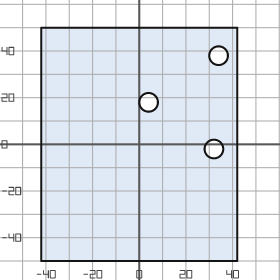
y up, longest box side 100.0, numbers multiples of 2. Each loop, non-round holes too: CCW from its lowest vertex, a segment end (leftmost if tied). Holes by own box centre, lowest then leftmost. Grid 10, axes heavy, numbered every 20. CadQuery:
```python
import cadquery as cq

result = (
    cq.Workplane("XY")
    .moveTo(-42.0, -50.0)
    .lineTo(42.0, -50.0)
    .lineTo(42.0, 50.0)
    .lineTo(-42.0, 50.0)
    .close()
    .moveTo(32.0, -2.0)
    .circle(4.0)
    .moveTo(4.0, 18.0)
    .circle(4.0)
    .moveTo(34.0, 38.0)
    .circle(4.0)
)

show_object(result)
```